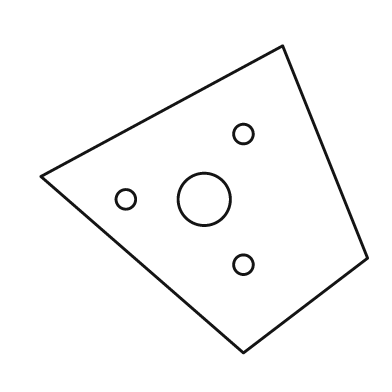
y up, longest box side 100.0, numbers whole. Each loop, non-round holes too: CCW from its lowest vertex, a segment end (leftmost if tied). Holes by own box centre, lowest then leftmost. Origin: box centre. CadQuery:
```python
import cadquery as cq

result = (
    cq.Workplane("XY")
    .moveTo(12.0, -47.0)
    .lineTo(50.0, -18.0)
    .lineTo(24.0, 47.0)
    .lineTo(-50.0, 7.0)
    .close()
    .moveTo(12.0, -20.0)
    .circle(3.0)
    .moveTo(-24.0, 0.0)
    .circle(3.0)
    .moveTo(0.0, 0.0)
    .circle(8.0)
    .moveTo(12.0, 20.0)
    .circle(3.0)
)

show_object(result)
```